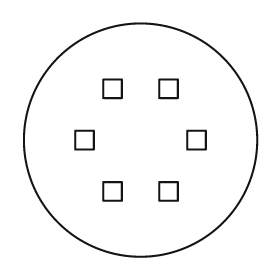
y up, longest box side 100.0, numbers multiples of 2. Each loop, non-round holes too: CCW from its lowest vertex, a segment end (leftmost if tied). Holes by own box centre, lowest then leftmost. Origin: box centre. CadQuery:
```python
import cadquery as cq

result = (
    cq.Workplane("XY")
    .moveTo(0.0, 0.0)
    .circle(50.0)
    .moveTo(-16.0, -26.0)
    .lineTo(-8.0, -26.0)
    .lineTo(-8.0, -18.0)
    .lineTo(-16.0, -18.0)
    .close()
    .moveTo(8.0, -26.0)
    .lineTo(16.0, -26.0)
    .lineTo(16.0, -18.0)
    .lineTo(8.0, -18.0)
    .close()
    .moveTo(-28.0, -4.0)
    .lineTo(-20.0, -4.0)
    .lineTo(-20.0, 4.0)
    .lineTo(-28.0, 4.0)
    .close()
    .moveTo(20.0, -4.0)
    .lineTo(28.0, -4.0)
    .lineTo(28.0, 4.0)
    .lineTo(20.0, 4.0)
    .close()
    .moveTo(-16.0, 18.0)
    .lineTo(-8.0, 18.0)
    .lineTo(-8.0, 26.0)
    .lineTo(-16.0, 26.0)
    .close()
    .moveTo(8.0, 18.0)
    .lineTo(16.0, 18.0)
    .lineTo(16.0, 26.0)
    .lineTo(8.0, 26.0)
    .close()
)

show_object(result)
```